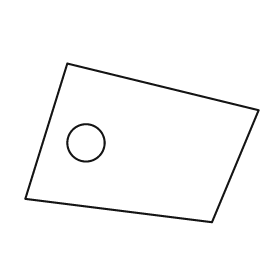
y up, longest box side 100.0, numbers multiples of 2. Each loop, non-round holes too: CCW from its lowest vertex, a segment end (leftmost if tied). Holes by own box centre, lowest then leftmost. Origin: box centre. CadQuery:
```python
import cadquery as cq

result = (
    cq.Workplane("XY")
    .moveTo(30.0, -34.0)
    .lineTo(50.0, 14.0)
    .lineTo(-32.0, 34.0)
    .lineTo(-50.0, -24.0)
    .close()
    .moveTo(-24.0, 0.0)
    .circle(8.0)
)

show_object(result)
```